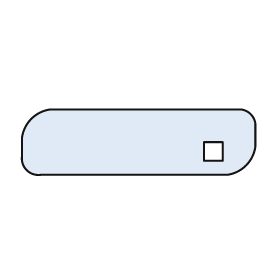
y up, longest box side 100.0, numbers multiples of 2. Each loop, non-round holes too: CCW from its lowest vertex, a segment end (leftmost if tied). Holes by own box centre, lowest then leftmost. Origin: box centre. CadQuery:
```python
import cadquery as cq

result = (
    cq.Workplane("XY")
    .moveTo(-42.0, -14.0)
    .lineTo(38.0, -14.0)
    .threePointArc((46.0, -10.0), (50.0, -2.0))
    .lineTo(50.0, 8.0)
    .threePointArc((48.0, 12.0), (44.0, 14.0))
    .lineTo(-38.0, 14.0)
    .threePointArc((-46.0, 10.0), (-50.0, 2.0))
    .lineTo(-50.0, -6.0)
    .threePointArc((-48.0, -12.0), (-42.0, -14.0))
    .close()
    .moveTo(28.0, -8.0)
    .lineTo(36.0, -8.0)
    .lineTo(36.0, 0.0)
    .lineTo(28.0, 0.0)
    .close()
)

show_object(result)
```